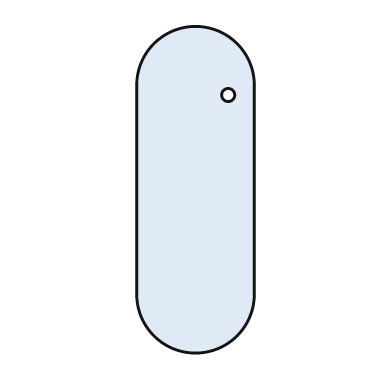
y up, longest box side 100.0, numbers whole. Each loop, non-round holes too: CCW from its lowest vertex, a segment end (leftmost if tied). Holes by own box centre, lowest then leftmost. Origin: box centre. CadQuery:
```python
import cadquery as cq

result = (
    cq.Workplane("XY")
    .moveTo(-18.0, -32.0)
    .threePointArc((0.0, -50.0), (18.0, -32.0))
    .lineTo(18.0, 32.0)
    .threePointArc((0.0, 50.0), (-18.0, 32.0))
    .close()
    .moveTo(10.0, 29.0)
    .circle(2.0)
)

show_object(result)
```